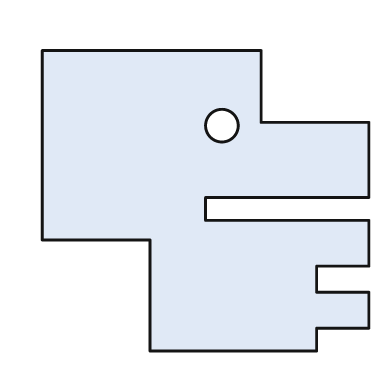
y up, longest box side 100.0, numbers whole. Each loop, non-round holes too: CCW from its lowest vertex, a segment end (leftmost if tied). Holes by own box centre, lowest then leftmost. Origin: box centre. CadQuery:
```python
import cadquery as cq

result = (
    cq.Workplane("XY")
    .moveTo(-17.0, -46.0)
    .lineTo(34.0, -46.0)
    .lineTo(34.0, -39.0)
    .lineTo(50.0, -39.0)
    .lineTo(50.0, -28.0)
    .lineTo(34.0, -28.0)
    .lineTo(34.0, -20.0)
    .lineTo(50.0, -20.0)
    .lineTo(50.0, -6.0)
    .lineTo(0.0, -6.0)
    .lineTo(0.0, 1.0)
    .lineTo(50.0, 1.0)
    .lineTo(50.0, 24.0)
    .lineTo(17.0, 24.0)
    .lineTo(17.0, 46.0)
    .lineTo(-50.0, 46.0)
    .lineTo(-50.0, -12.0)
    .lineTo(-17.0, -12.0)
    .close()
    .moveTo(5.0, 23.0)
    .circle(5.0)
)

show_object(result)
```